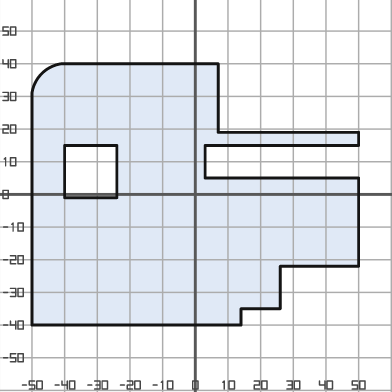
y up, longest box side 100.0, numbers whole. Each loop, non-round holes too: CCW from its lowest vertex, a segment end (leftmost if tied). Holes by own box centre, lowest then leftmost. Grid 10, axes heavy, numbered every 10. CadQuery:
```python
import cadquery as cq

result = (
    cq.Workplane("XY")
    .moveTo(-50.0, -40.0)
    .lineTo(14.0, -40.0)
    .lineTo(14.0, -35.0)
    .lineTo(26.0, -35.0)
    .lineTo(26.0, -22.0)
    .lineTo(50.0, -22.0)
    .lineTo(50.0, 5.0)
    .lineTo(3.0, 5.0)
    .lineTo(3.0, 15.0)
    .lineTo(50.0, 15.0)
    .lineTo(50.0, 19.0)
    .lineTo(7.0, 19.0)
    .lineTo(7.0, 40.0)
    .lineTo(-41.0, 40.0)
    .threePointArc((-47.0, 37.0), (-50.0, 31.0))
    .close()
    .moveTo(-40.0, -1.0)
    .lineTo(-24.0, -1.0)
    .lineTo(-24.0, 15.0)
    .lineTo(-40.0, 15.0)
    .close()
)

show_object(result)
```